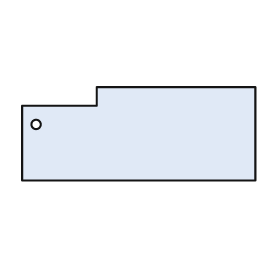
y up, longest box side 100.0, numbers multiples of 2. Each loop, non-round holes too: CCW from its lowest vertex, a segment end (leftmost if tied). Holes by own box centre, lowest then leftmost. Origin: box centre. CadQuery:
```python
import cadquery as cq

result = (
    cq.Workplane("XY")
    .moveTo(-50.0, -20.0)
    .lineTo(50.0, -20.0)
    .lineTo(50.0, 20.0)
    .lineTo(-18.0, 20.0)
    .lineTo(-18.0, 12.0)
    .lineTo(-50.0, 12.0)
    .close()
    .moveTo(-44.0, 4.0)
    .circle(2.0)
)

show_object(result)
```